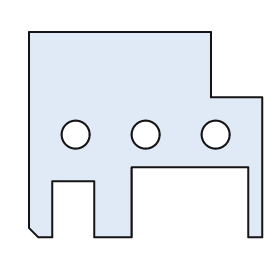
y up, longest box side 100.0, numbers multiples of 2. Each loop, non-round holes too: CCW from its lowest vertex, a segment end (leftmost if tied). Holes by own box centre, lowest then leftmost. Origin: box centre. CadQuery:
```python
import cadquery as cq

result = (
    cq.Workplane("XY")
    .moveTo(-46.0, -44.0)
    .lineTo(-40.0, -44.0)
    .lineTo(-40.0, -20.0)
    .lineTo(-22.0, -20.0)
    .lineTo(-22.0, -44.0)
    .lineTo(-6.0, -44.0)
    .lineTo(-6.0, -14.0)
    .lineTo(44.0, -14.0)
    .lineTo(44.0, -44.0)
    .lineTo(50.0, -44.0)
    .lineTo(50.0, 16.0)
    .lineTo(28.0, 16.0)
    .lineTo(28.0, 44.0)
    .lineTo(-50.0, 44.0)
    .lineTo(-50.0, -40.0)
    .close()
    .moveTo(-30.0, 0.0)
    .circle(6.0)
    .moveTo(0.0, 0.0)
    .circle(6.0)
    .moveTo(30.0, 0.0)
    .circle(6.0)
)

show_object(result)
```